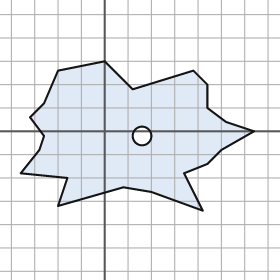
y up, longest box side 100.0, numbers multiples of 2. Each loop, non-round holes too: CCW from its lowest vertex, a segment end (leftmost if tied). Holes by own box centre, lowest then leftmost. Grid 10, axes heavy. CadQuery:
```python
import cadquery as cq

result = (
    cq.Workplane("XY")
    .moveTo(42.0, -34.0)
    .lineTo(34.0, -18.0)
    .lineTo(44.0, -14.0)
    .lineTo(50.0, -8.0)
    .lineTo(64.0, 0.0)
    .lineTo(52.0, 4.0)
    .lineTo(44.0, 10.0)
    .lineTo(44.0, 20.0)
    .lineTo(38.0, 26.0)
    .lineTo(12.0, 18.0)
    .lineTo(0.0, 30.0)
    .lineTo(-20.0, 26.0)
    .lineTo(-26.0, 12.0)
    .lineTo(-32.0, 6.0)
    .lineTo(-26.0, -2.0)
    .lineTo(-28.0, -8.0)
    .lineTo(-36.0, -18.0)
    .lineTo(-16.0, -20.0)
    .lineTo(-20.0, -32.0)
    .lineTo(8.0, -24.0)
    .lineTo(20.0, -26.0)
    .close()
    .moveTo(16.0, -2.0)
    .circle(4.0)
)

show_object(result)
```